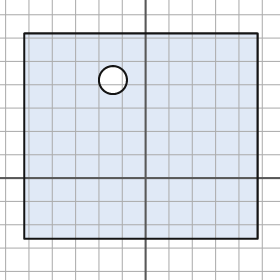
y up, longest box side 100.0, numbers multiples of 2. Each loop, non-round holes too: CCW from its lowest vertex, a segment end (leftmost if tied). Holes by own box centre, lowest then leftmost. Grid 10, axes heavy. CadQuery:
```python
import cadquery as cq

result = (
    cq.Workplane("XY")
    .moveTo(-52.0, -26.0)
    .lineTo(48.0, -26.0)
    .lineTo(48.0, 62.0)
    .lineTo(-52.0, 62.0)
    .close()
    .moveTo(-14.0, 42.0)
    .circle(6.0)
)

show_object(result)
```